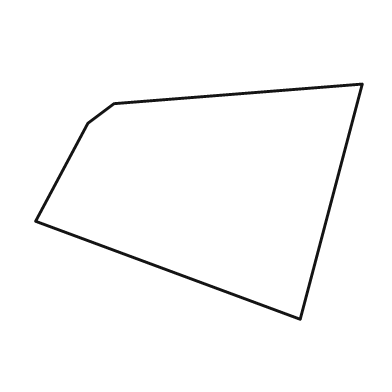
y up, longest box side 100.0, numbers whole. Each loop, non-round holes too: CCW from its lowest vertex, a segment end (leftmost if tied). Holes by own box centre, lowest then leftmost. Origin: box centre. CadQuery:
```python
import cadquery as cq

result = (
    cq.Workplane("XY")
    .moveTo(31.0, -36.0)
    .lineTo(50.0, 36.0)
    .lineTo(-26.0, 30.0)
    .lineTo(-34.0, 24.0)
    .lineTo(-50.0, -6.0)
    .close()
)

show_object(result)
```